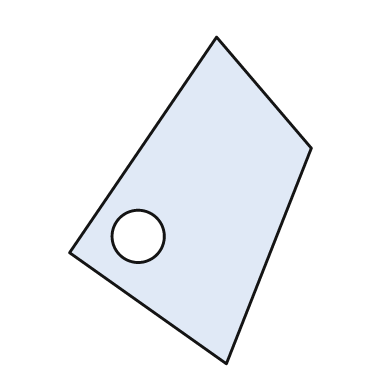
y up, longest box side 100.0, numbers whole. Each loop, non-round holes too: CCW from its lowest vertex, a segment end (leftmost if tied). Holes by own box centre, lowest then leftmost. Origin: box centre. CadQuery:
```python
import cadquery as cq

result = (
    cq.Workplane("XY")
    .moveTo(11.0, -50.0)
    .lineTo(37.0, 16.0)
    .lineTo(8.0, 50.0)
    .lineTo(-37.0, -16.0)
    .close()
    .moveTo(-16.0, -11.0)
    .circle(8.0)
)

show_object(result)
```